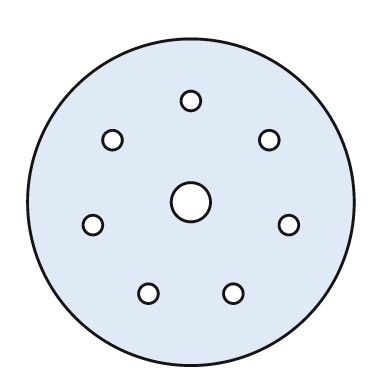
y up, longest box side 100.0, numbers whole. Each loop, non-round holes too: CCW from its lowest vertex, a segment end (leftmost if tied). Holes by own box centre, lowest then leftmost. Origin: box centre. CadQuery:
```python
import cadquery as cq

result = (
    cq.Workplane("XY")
    .moveTo(0.0, 0.0)
    .circle(50.0)
    .moveTo(-13.0, -28.0)
    .circle(3.0)
    .moveTo(13.0, -28.0)
    .circle(3.0)
    .moveTo(-30.0, -7.0)
    .circle(3.0)
    .moveTo(30.0, -7.0)
    .circle(3.0)
    .moveTo(0.0, 0.0)
    .circle(6.0)
    .moveTo(-24.0, 19.0)
    .circle(3.0)
    .moveTo(24.0, 19.0)
    .circle(3.0)
    .moveTo(0.0, 31.0)
    .circle(3.0)
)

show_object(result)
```